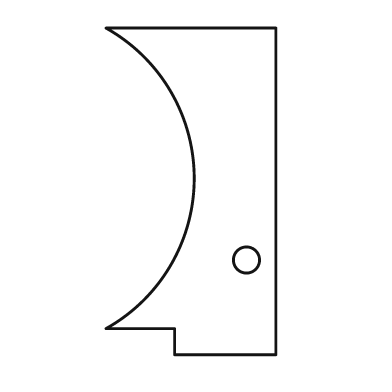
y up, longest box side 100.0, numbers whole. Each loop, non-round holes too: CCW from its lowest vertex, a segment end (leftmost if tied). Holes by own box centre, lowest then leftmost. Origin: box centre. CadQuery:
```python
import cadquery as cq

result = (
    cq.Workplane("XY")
    .moveTo(-5.0, -50.0)
    .lineTo(26.0, -50.0)
    .lineTo(26.0, 50.0)
    .lineTo(-26.0, 50.0)
    .threePointArc((1.0, 4.0), (-26.0, -42.0))
    .lineTo(-5.0, -42.0)
    .close()
    .moveTo(17.0, -21.0)
    .circle(4.0)
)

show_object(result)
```